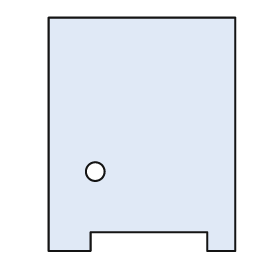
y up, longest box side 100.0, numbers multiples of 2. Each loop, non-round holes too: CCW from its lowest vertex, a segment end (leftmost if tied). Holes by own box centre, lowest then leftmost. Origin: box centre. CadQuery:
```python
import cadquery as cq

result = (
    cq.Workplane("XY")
    .moveTo(-40.0, -50.0)
    .lineTo(-22.0, -50.0)
    .lineTo(-22.0, -42.0)
    .lineTo(28.0, -42.0)
    .lineTo(28.0, -50.0)
    .lineTo(40.0, -50.0)
    .lineTo(40.0, 50.0)
    .lineTo(-40.0, 50.0)
    .close()
    .moveTo(-20.0, -16.0)
    .circle(4.0)
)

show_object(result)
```